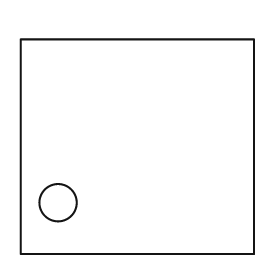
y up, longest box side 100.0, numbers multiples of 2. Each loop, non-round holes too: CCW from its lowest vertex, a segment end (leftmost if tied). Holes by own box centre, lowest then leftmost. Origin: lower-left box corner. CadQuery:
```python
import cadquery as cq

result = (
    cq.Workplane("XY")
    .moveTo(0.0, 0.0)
    .lineTo(100.0, 0.0)
    .lineTo(100.0, 92.0)
    .lineTo(0.0, 92.0)
    .close()
    .moveTo(16.0, 22.0)
    .circle(8.0)
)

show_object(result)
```